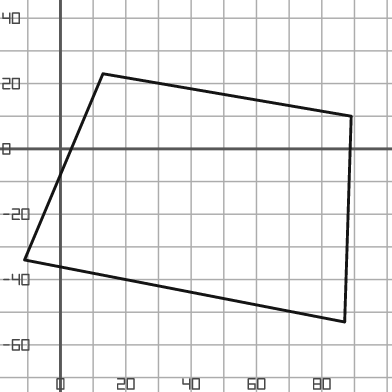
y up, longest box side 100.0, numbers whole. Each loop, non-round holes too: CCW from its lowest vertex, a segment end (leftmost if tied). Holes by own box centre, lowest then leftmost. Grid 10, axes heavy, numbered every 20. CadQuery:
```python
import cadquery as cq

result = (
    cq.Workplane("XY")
    .moveTo(87.0, -53.0)
    .lineTo(89.0, 10.0)
    .lineTo(13.0, 23.0)
    .lineTo(-11.0, -34.0)
    .close()
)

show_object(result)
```